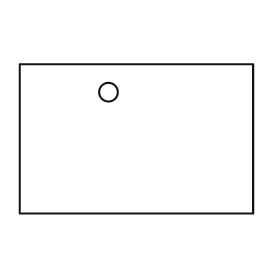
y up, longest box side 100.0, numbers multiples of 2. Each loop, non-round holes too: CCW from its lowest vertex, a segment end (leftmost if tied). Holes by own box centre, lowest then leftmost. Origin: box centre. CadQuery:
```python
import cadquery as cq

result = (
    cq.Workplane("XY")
    .moveTo(-50.0, -32.0)
    .lineTo(50.0, -32.0)
    .lineTo(50.0, 32.0)
    .lineTo(-50.0, 32.0)
    .close()
    .moveTo(-12.0, 20.0)
    .circle(4.0)
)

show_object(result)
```